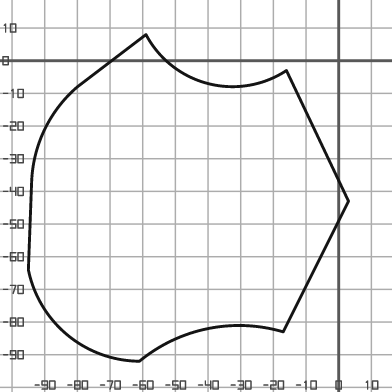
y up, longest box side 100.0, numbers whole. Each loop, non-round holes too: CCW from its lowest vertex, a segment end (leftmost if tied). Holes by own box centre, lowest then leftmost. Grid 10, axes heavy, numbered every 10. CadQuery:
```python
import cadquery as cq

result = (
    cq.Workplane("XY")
    .moveTo(-61.0, -92.0)
    .threePointArc((-40.0, -82.0), (-17.0, -83.0))
    .lineTo(3.0, -43.0)
    .lineTo(-16.0, -3.0)
    .threePointArc((-40.0, -7.0), (-59.0, 8.0))
    .lineTo(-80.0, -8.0)
    .threePointArc((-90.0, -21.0), (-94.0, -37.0))
    .lineTo(-95.0, -64.0)
    .threePointArc((-83.0, -84.0), (-61.0, -92.0))
    .close()
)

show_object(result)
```